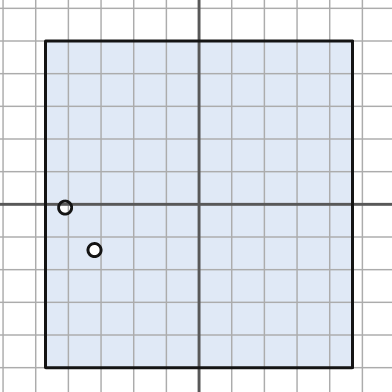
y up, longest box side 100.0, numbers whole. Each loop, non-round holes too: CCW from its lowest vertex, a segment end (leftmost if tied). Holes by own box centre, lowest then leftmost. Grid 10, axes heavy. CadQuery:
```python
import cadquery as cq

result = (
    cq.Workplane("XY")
    .moveTo(-47.0, -50.0)
    .lineTo(47.0, -50.0)
    .lineTo(47.0, 50.0)
    .lineTo(-47.0, 50.0)
    .close()
    .moveTo(-32.0, -14.0)
    .circle(2.0)
    .moveTo(-41.0, -1.0)
    .circle(2.0)
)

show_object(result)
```